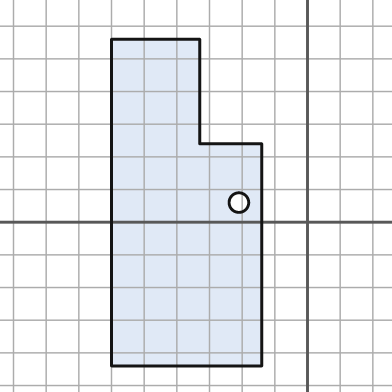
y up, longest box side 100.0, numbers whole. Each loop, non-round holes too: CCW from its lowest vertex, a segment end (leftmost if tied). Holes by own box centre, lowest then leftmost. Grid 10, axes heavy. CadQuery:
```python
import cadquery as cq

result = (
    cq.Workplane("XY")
    .moveTo(-60.0, -44.0)
    .lineTo(-14.0, -44.0)
    .lineTo(-14.0, 24.0)
    .lineTo(-33.0, 24.0)
    .lineTo(-33.0, 56.0)
    .lineTo(-60.0, 56.0)
    .close()
    .moveTo(-21.0, 6.0)
    .circle(3.0)
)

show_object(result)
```